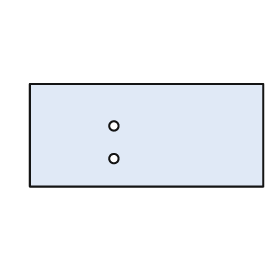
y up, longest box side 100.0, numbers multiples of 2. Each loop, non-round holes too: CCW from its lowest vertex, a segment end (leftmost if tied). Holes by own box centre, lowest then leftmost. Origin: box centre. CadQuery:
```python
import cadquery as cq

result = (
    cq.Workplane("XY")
    .moveTo(-50.0, -22.0)
    .lineTo(50.0, -22.0)
    .lineTo(50.0, 22.0)
    .lineTo(-50.0, 22.0)
    .close()
    .moveTo(-14.0, -10.0)
    .circle(2.0)
    .moveTo(-14.0, 4.0)
    .circle(2.0)
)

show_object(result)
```